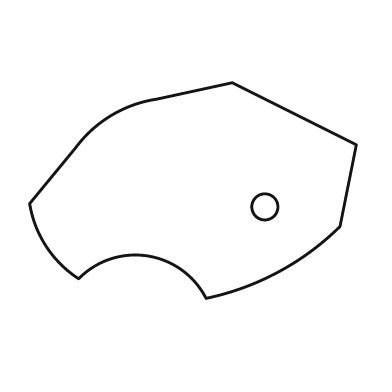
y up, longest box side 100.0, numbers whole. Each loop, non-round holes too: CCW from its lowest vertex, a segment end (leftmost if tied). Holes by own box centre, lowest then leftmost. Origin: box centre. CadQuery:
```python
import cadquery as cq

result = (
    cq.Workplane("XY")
    .moveTo(4.0, -33.0)
    .threePointArc((26.0, -25.0), (45.0, -11.0))
    .lineTo(50.0, 14.0)
    .lineTo(12.0, 33.0)
    .lineTo(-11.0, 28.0)
    .threePointArc((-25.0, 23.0), (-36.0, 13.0))
    .lineTo(-50.0, -4.0)
    .threePointArc((-45.0, -17.0), (-35.0, -27.0))
    .threePointArc((-14.0, -20.0), (4.0, -33.0))
    .close()
    .moveTo(22.0, -5.0)
    .circle(4.0)
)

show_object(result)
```